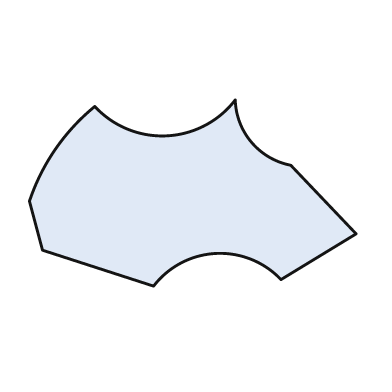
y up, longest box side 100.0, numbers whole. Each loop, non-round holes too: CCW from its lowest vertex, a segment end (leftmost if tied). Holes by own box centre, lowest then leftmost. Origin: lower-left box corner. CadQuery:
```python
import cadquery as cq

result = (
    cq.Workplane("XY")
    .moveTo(38.0, 0.0)
    .threePointArc((57.0, 10.0), (77.0, 2.0))
    .lineTo(100.0, 16.0)
    .lineTo(80.0, 37.0)
    .threePointArc((68.0, 44.0), (63.0, 57.0))
    .threePointArc((42.0, 46.0), (20.0, 55.0))
    .threePointArc((8.0, 42.0), (0.0, 26.0))
    .lineTo(4.0, 11.0)
    .close()
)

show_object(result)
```